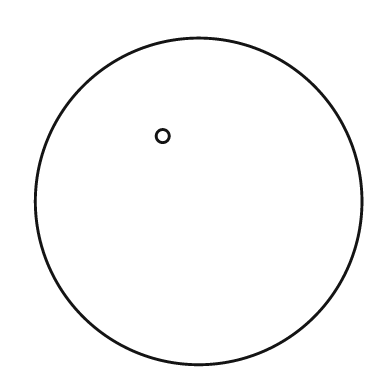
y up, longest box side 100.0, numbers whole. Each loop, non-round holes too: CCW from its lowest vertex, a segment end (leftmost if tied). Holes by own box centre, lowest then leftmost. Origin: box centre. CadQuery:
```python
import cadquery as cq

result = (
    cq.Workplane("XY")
    .moveTo(0.0, 0.0)
    .circle(50.0)
    .moveTo(-11.0, 20.0)
    .circle(2.0)
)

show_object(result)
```